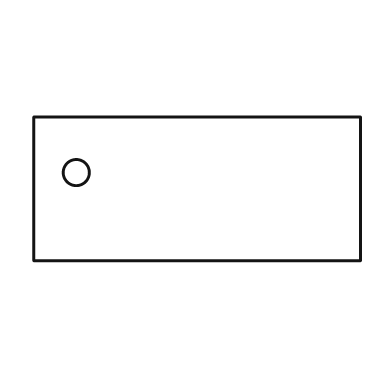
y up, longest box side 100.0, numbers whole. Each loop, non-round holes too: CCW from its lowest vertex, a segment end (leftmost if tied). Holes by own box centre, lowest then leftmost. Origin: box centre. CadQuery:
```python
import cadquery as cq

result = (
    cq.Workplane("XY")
    .moveTo(-50.0, -22.0)
    .lineTo(50.0, -22.0)
    .lineTo(50.0, 22.0)
    .lineTo(-50.0, 22.0)
    .close()
    .moveTo(-37.0, 5.0)
    .circle(4.0)
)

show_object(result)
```